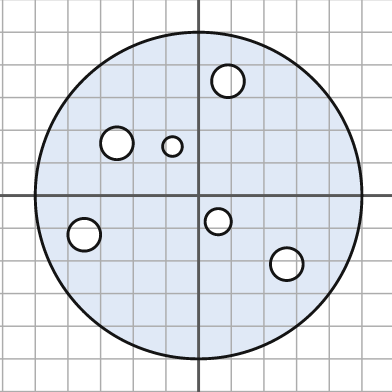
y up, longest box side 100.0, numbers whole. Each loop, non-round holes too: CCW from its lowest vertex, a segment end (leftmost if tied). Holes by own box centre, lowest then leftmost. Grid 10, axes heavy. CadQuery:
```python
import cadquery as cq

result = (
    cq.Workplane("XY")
    .moveTo(0.0, 0.0)
    .circle(50.0)
    .moveTo(27.0, -21.0)
    .circle(5.0)
    .moveTo(-35.0, -12.0)
    .circle(5.0)
    .moveTo(6.0, -8.0)
    .circle(4.0)
    .moveTo(-8.0, 15.0)
    .circle(3.0)
    .moveTo(-25.0, 16.0)
    .circle(5.0)
    .moveTo(9.0, 35.0)
    .circle(5.0)
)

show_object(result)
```